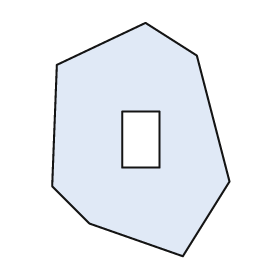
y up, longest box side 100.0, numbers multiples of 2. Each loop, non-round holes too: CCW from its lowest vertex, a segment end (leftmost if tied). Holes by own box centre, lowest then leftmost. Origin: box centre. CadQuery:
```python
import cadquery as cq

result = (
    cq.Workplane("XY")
    .moveTo(18.0, -50.0)
    .lineTo(38.0, -18.0)
    .lineTo(24.0, 36.0)
    .lineTo(2.0, 50.0)
    .lineTo(-36.0, 32.0)
    .lineTo(-38.0, -20.0)
    .lineTo(-22.0, -36.0)
    .close()
    .moveTo(-8.0, -12.0)
    .lineTo(8.0, -12.0)
    .lineTo(8.0, 12.0)
    .lineTo(-8.0, 12.0)
    .close()
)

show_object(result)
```